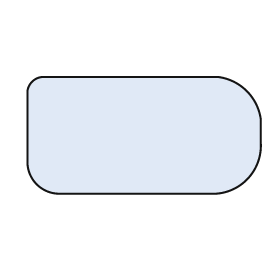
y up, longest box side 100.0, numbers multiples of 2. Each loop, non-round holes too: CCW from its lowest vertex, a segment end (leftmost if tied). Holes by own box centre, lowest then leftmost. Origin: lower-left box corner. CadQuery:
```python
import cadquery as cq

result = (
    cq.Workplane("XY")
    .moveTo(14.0, 0.0)
    .lineTo(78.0, 0.0)
    .threePointArc((94.0, 6.0), (100.0, 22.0))
    .lineTo(100.0, 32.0)
    .threePointArc((94.0, 44.0), (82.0, 50.0))
    .lineTo(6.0, 50.0)
    .threePointArc((2.0, 48.0), (0.0, 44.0))
    .lineTo(0.0, 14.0)
    .threePointArc((4.0, 4.0), (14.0, 0.0))
    .close()
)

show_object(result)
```